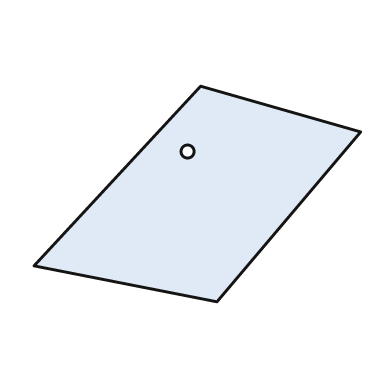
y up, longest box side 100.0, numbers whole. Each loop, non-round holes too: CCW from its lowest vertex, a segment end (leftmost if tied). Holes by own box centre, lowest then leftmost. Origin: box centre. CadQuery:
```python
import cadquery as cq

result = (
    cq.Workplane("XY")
    .moveTo(6.0, -33.0)
    .lineTo(50.0, 19.0)
    .lineTo(1.0, 33.0)
    .lineTo(-50.0, -22.0)
    .close()
    .moveTo(-3.0, 13.0)
    .circle(2.0)
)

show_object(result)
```